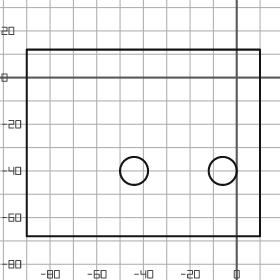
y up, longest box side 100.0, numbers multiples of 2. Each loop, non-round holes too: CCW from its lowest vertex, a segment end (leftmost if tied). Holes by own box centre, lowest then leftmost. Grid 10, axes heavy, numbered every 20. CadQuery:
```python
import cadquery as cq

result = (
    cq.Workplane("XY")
    .moveTo(-90.0, -68.0)
    .lineTo(10.0, -68.0)
    .lineTo(10.0, 12.0)
    .lineTo(-90.0, 12.0)
    .close()
    .moveTo(-44.0, -40.0)
    .circle(6.0)
    .moveTo(-6.0, -40.0)
    .circle(6.0)
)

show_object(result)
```